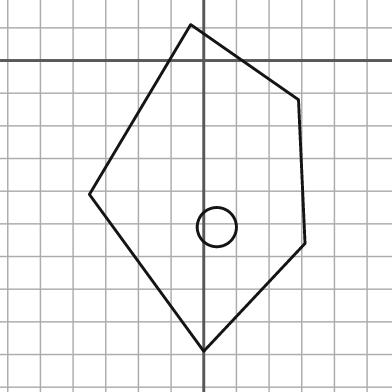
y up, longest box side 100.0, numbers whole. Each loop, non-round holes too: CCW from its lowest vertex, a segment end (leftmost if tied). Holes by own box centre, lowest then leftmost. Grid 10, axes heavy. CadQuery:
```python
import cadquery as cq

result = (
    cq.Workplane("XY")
    .moveTo(0.0, -89.0)
    .lineTo(31.0, -56.0)
    .lineTo(29.0, -12.0)
    .lineTo(-4.0, 11.0)
    .lineTo(-35.0, -41.0)
    .close()
    .moveTo(4.0, -51.0)
    .circle(6.0)
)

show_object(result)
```